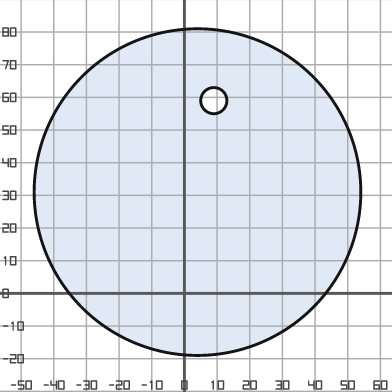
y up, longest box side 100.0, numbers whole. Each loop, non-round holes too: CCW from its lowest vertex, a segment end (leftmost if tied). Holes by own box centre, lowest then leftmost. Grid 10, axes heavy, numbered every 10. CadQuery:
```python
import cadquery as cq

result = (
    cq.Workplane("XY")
    .moveTo(4.0, 31.0)
    .circle(50.0)
    .moveTo(9.0, 59.0)
    .circle(4.0)
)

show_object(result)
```